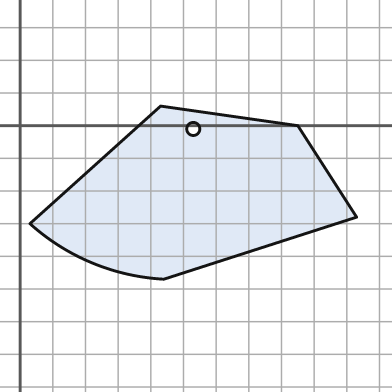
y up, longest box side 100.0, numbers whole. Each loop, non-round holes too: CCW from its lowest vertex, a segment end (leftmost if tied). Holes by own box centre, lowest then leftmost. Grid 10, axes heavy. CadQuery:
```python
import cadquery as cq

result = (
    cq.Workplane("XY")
    .moveTo(44.0, -47.0)
    .lineTo(103.0, -28.0)
    .lineTo(85.0, 0.0)
    .lineTo(43.0, 6.0)
    .lineTo(3.0, -30.0)
    .threePointArc((22.0, -42.0), (44.0, -47.0))
    .close()
    .moveTo(53.0, -1.0)
    .circle(2.0)
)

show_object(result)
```